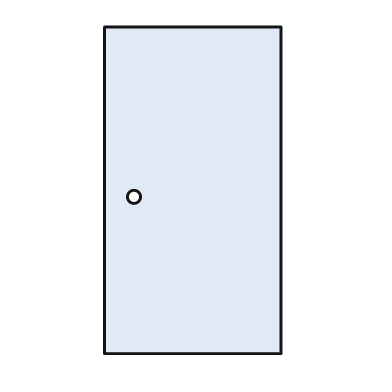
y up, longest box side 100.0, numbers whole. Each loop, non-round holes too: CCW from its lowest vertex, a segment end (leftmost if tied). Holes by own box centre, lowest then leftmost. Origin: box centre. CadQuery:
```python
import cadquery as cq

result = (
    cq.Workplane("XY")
    .moveTo(-27.0, -50.0)
    .lineTo(27.0, -50.0)
    .lineTo(27.0, 50.0)
    .lineTo(-27.0, 50.0)
    .close()
    .moveTo(-18.0, -2.0)
    .circle(2.0)
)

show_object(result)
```